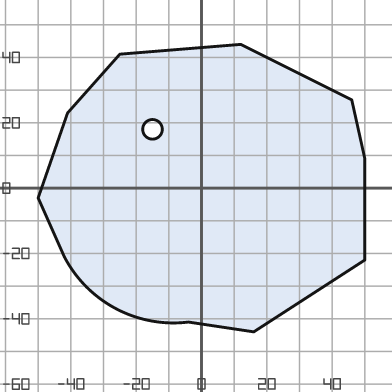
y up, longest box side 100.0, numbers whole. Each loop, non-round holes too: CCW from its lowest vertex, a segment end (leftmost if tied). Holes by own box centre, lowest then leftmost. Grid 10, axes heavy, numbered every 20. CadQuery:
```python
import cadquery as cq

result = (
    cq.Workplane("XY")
    .moveTo(16.0, -44.0)
    .lineTo(50.0, -22.0)
    .lineTo(50.0, 9.0)
    .lineTo(46.0, 27.0)
    .lineTo(12.0, 44.0)
    .lineTo(-25.0, 41.0)
    .lineTo(-41.0, 23.0)
    .lineTo(-50.0, -3.0)
    .lineTo(-42.0, -21.0)
    .threePointArc((-26.0, -37.0), (-4.0, -41.0))
    .close()
    .moveTo(-15.0, 18.0)
    .circle(3.0)
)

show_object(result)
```